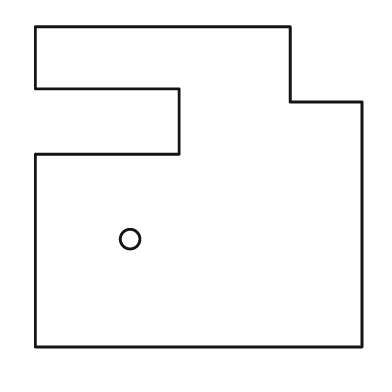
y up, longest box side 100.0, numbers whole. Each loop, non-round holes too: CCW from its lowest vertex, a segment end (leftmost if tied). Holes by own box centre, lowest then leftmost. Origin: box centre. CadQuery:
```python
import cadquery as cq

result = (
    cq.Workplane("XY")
    .moveTo(-50.0, -49.0)
    .lineTo(50.0, -49.0)
    .lineTo(50.0, 26.0)
    .lineTo(28.0, 26.0)
    .lineTo(28.0, 49.0)
    .lineTo(-50.0, 49.0)
    .lineTo(-50.0, 30.0)
    .lineTo(-6.0, 30.0)
    .lineTo(-6.0, 10.0)
    .lineTo(-50.0, 10.0)
    .close()
    .moveTo(-21.0, -16.0)
    .circle(3.0)
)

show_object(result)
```